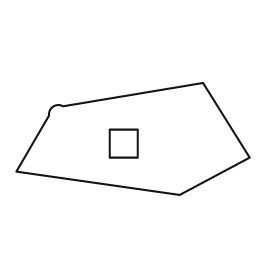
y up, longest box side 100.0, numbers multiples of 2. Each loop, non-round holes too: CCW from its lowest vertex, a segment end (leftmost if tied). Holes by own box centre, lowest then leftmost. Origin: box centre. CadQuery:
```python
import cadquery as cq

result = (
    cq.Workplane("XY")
    .moveTo(20.0, -24.0)
    .lineTo(50.0, -8.0)
    .lineTo(30.0, 24.0)
    .lineTo(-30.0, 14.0)
    .threePointArc((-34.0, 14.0), (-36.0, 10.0))
    .lineTo(-50.0, -14.0)
    .close()
    .moveTo(-10.0, -8.0)
    .lineTo(2.0, -8.0)
    .lineTo(2.0, 4.0)
    .lineTo(-10.0, 4.0)
    .close()
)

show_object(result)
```